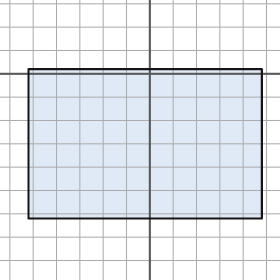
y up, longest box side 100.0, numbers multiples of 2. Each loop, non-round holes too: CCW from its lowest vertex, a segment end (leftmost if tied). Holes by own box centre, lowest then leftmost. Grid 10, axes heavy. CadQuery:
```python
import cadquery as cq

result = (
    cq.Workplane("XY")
    .moveTo(-52.0, -62.0)
    .lineTo(48.0, -62.0)
    .lineTo(48.0, 2.0)
    .lineTo(-52.0, 2.0)
    .close()
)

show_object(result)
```